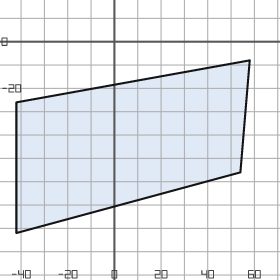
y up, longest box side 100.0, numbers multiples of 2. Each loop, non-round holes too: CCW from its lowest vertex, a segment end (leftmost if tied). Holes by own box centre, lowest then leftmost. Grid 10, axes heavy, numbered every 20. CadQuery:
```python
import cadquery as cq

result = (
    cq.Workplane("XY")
    .moveTo(-42.0, -82.0)
    .lineTo(54.0, -56.0)
    .lineTo(58.0, -8.0)
    .lineTo(-42.0, -26.0)
    .close()
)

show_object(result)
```